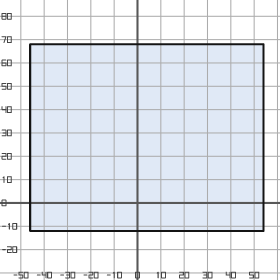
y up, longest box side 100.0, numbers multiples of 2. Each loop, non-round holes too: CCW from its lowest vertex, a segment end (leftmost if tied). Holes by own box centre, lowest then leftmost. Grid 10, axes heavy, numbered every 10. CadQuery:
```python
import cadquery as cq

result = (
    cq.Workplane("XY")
    .moveTo(-46.0, -12.0)
    .lineTo(54.0, -12.0)
    .lineTo(54.0, 68.0)
    .lineTo(-46.0, 68.0)
    .close()
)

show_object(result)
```